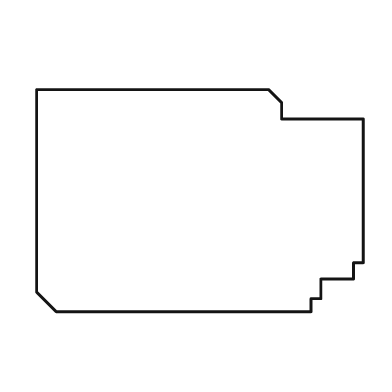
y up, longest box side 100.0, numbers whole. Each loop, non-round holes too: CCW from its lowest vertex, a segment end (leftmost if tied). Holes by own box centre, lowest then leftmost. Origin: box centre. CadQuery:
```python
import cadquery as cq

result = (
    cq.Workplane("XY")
    .moveTo(-44.0, -34.0)
    .lineTo(34.0, -34.0)
    .lineTo(34.0, -30.0)
    .lineTo(37.0, -30.0)
    .lineTo(37.0, -24.0)
    .lineTo(47.0, -24.0)
    .lineTo(47.0, -19.0)
    .lineTo(50.0, -19.0)
    .lineTo(50.0, 25.0)
    .lineTo(25.0, 25.0)
    .lineTo(25.0, 30.0)
    .lineTo(21.0, 34.0)
    .lineTo(-50.0, 34.0)
    .lineTo(-50.0, -28.0)
    .close()
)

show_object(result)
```